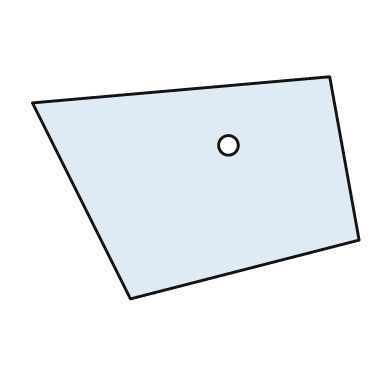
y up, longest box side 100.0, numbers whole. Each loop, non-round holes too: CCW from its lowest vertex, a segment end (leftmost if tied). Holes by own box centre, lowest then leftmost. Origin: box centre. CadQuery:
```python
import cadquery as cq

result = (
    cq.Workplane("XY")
    .moveTo(-20.0, -34.0)
    .lineTo(50.0, -16.0)
    .lineTo(41.0, 34.0)
    .lineTo(-50.0, 26.0)
    .close()
    .moveTo(10.0, 13.0)
    .circle(3.0)
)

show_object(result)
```